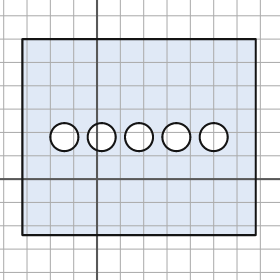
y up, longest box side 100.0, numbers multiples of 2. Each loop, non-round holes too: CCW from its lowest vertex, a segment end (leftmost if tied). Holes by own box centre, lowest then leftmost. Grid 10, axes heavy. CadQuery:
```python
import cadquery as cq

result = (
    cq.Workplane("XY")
    .moveTo(-32.0, -24.0)
    .lineTo(68.0, -24.0)
    .lineTo(68.0, 60.0)
    .lineTo(-32.0, 60.0)
    .close()
    .moveTo(-14.0, 18.0)
    .circle(6.0)
    .moveTo(2.0, 18.0)
    .circle(6.0)
    .moveTo(18.0, 18.0)
    .circle(6.0)
    .moveTo(34.0, 18.0)
    .circle(6.0)
    .moveTo(50.0, 18.0)
    .circle(6.0)
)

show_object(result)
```